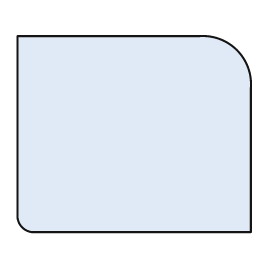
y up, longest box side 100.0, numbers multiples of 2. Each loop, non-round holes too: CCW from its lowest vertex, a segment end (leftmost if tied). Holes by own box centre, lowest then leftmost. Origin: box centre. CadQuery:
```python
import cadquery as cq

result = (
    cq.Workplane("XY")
    .moveTo(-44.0, -42.0)
    .lineTo(50.0, -42.0)
    .lineTo(50.0, 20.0)
    .threePointArc((44.0, 36.0), (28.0, 42.0))
    .lineTo(-50.0, 42.0)
    .lineTo(-50.0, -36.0)
    .threePointArc((-48.0, -40.0), (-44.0, -42.0))
    .close()
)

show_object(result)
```